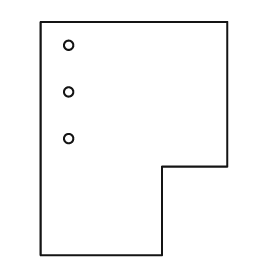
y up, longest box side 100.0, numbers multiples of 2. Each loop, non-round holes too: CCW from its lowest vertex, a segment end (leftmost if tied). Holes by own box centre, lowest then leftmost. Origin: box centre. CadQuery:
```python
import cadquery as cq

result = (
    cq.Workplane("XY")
    .moveTo(-40.0, -50.0)
    .lineTo(12.0, -50.0)
    .lineTo(12.0, -12.0)
    .lineTo(40.0, -12.0)
    .lineTo(40.0, 50.0)
    .lineTo(-40.0, 50.0)
    .close()
    .moveTo(-28.0, 0.0)
    .circle(2.0)
    .moveTo(-28.0, 20.0)
    .circle(2.0)
    .moveTo(-28.0, 40.0)
    .circle(2.0)
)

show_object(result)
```